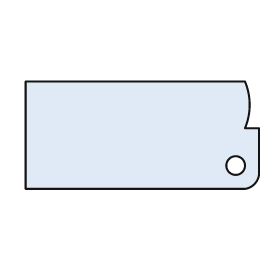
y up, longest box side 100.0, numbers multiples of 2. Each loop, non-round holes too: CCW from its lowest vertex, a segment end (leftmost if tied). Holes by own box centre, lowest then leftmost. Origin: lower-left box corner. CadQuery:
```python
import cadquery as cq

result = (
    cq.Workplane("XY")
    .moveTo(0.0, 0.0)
    .lineTo(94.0, 0.0)
    .threePointArc((98.0, 2.0), (100.0, 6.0))
    .lineTo(100.0, 26.0)
    .lineTo(94.0, 26.0)
    .threePointArc((96.0, 36.0), (94.0, 46.0))
    .lineTo(0.0, 46.0)
    .close()
    .moveTo(90.0, 10.0)
    .circle(4.0)
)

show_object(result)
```